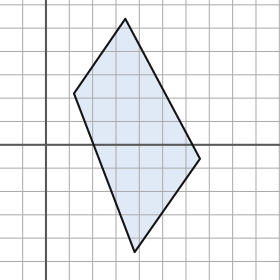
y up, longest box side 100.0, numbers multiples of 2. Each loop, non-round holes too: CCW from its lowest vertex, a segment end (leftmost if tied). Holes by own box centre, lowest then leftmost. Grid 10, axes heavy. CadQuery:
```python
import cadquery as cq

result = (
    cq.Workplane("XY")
    .moveTo(38.0, -46.0)
    .lineTo(66.0, -6.0)
    .lineTo(34.0, 54.0)
    .lineTo(12.0, 22.0)
    .close()
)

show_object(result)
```